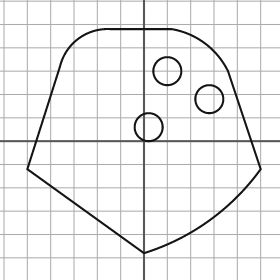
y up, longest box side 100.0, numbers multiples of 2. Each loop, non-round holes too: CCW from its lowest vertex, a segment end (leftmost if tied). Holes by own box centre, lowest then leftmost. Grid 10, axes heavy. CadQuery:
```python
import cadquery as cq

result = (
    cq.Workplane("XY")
    .moveTo(0.0, -48.0)
    .threePointArc((28.0, -34.0), (50.0, -12.0))
    .lineTo(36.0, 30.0)
    .threePointArc((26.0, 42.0), (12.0, 48.0))
    .lineTo(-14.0, 48.0)
    .threePointArc((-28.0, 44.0), (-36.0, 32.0))
    .lineTo(-50.0, -12.0)
    .close()
    .moveTo(2.0, 6.0)
    .circle(6.0)
    .moveTo(28.0, 18.0)
    .circle(6.0)
    .moveTo(10.0, 30.0)
    .circle(6.0)
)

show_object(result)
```